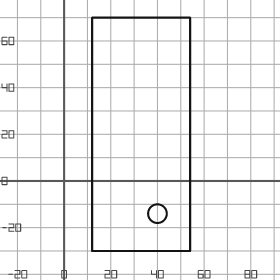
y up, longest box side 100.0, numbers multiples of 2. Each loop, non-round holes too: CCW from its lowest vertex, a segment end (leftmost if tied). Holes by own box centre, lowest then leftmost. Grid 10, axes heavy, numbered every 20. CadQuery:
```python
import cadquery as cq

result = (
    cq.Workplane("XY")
    .moveTo(12.0, -30.0)
    .lineTo(54.0, -30.0)
    .lineTo(54.0, 70.0)
    .lineTo(12.0, 70.0)
    .close()
    .moveTo(40.0, -14.0)
    .circle(4.0)
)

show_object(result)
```